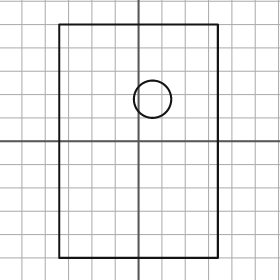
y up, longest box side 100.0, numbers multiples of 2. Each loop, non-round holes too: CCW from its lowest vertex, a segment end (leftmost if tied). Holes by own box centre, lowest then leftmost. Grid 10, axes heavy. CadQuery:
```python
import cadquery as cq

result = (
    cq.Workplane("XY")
    .moveTo(-34.0, -50.0)
    .lineTo(34.0, -50.0)
    .lineTo(34.0, 50.0)
    .lineTo(-34.0, 50.0)
    .close()
    .moveTo(6.0, 18.0)
    .circle(8.0)
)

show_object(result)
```